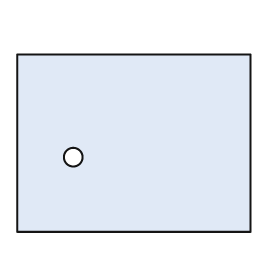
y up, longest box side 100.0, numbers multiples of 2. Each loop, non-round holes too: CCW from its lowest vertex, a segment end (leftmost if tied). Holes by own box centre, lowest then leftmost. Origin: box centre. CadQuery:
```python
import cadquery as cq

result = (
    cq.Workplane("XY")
    .moveTo(-50.0, -38.0)
    .lineTo(50.0, -38.0)
    .lineTo(50.0, 38.0)
    .lineTo(-50.0, 38.0)
    .close()
    .moveTo(-26.0, -6.0)
    .circle(4.0)
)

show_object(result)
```